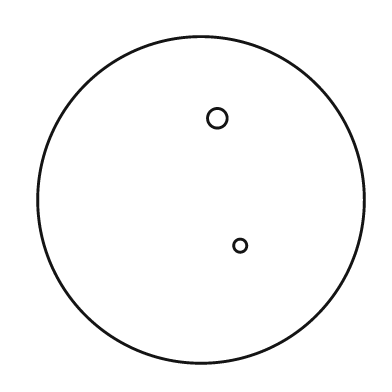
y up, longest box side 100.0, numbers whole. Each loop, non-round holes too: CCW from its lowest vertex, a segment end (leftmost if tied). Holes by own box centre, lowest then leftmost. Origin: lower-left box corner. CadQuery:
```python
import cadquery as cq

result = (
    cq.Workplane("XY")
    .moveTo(50.0, 50.0)
    .circle(50.0)
    .moveTo(62.0, 36.0)
    .circle(2.0)
    .moveTo(55.0, 75.0)
    .circle(3.0)
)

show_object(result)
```